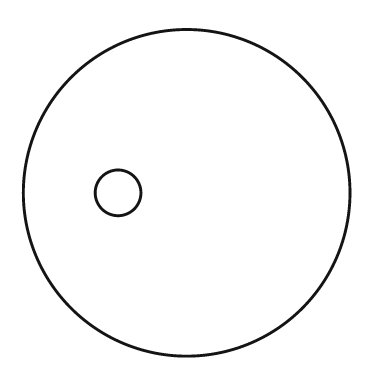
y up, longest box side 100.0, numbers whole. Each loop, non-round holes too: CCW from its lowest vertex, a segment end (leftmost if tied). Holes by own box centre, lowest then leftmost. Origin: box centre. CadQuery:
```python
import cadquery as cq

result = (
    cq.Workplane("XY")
    .moveTo(0.0, 0.0)
    .circle(50.0)
    .moveTo(-21.0, 0.0)
    .circle(7.0)
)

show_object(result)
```